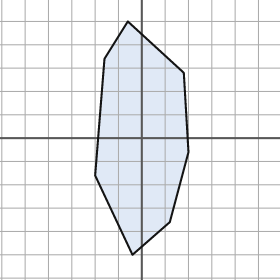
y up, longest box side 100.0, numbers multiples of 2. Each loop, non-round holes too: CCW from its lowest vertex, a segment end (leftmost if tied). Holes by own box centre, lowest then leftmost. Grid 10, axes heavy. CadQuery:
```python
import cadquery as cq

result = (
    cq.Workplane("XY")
    .moveTo(-4.0, -50.0)
    .lineTo(12.0, -36.0)
    .lineTo(20.0, -6.0)
    .lineTo(18.0, 28.0)
    .lineTo(-6.0, 50.0)
    .lineTo(-16.0, 34.0)
    .lineTo(-20.0, -16.0)
    .close()
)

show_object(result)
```